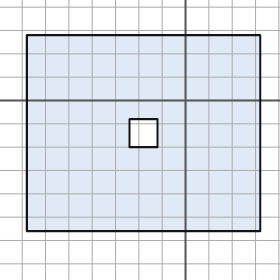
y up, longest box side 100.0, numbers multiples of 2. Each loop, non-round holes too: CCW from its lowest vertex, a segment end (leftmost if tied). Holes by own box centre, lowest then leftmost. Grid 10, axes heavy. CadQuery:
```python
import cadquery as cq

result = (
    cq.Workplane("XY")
    .moveTo(-68.0, -56.0)
    .lineTo(32.0, -56.0)
    .lineTo(32.0, 28.0)
    .lineTo(-68.0, 28.0)
    .close()
    .moveTo(-24.0, -20.0)
    .lineTo(-12.0, -20.0)
    .lineTo(-12.0, -8.0)
    .lineTo(-24.0, -8.0)
    .close()
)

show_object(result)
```